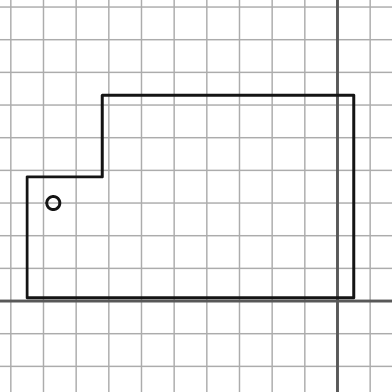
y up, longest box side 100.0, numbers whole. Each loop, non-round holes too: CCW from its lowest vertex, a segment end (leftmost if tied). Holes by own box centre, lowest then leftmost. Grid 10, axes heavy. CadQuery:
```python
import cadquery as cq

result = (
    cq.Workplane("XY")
    .moveTo(-95.0, 1.0)
    .lineTo(5.0, 1.0)
    .lineTo(5.0, 63.0)
    .lineTo(-72.0, 63.0)
    .lineTo(-72.0, 38.0)
    .lineTo(-95.0, 38.0)
    .close()
    .moveTo(-87.0, 30.0)
    .circle(2.0)
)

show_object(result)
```